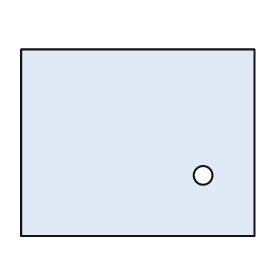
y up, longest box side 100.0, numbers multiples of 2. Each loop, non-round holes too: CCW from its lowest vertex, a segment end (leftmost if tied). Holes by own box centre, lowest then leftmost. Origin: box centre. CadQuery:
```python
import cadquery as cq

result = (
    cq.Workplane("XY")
    .moveTo(-50.0, -40.0)
    .lineTo(50.0, -40.0)
    .lineTo(50.0, 40.0)
    .lineTo(-50.0, 40.0)
    .close()
    .moveTo(28.0, -14.0)
    .circle(4.0)
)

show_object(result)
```